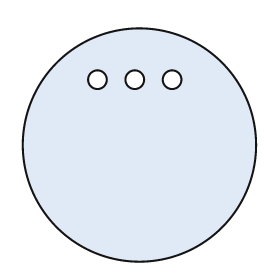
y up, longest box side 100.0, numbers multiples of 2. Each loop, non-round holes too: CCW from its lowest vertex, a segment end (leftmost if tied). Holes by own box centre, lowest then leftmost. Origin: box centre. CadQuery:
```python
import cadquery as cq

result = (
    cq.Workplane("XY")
    .moveTo(0.0, 0.0)
    .circle(50.0)
    .moveTo(-18.0, 28.0)
    .circle(4.0)
    .moveTo(-2.0, 28.0)
    .circle(4.0)
    .moveTo(14.0, 28.0)
    .circle(4.0)
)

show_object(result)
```